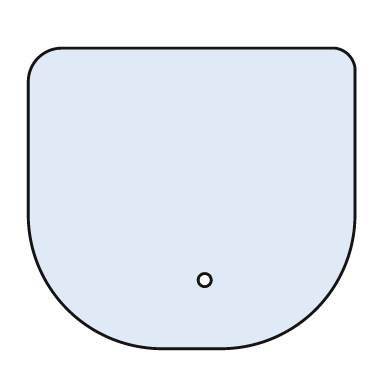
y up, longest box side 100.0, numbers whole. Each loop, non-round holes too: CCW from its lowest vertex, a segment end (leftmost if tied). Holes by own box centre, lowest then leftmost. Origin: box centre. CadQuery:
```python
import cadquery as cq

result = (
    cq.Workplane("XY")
    .moveTo(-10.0, -46.0)
    .lineTo(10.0, -46.0)
    .threePointArc((38.0, -34.0), (50.0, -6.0))
    .lineTo(50.0, 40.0)
    .threePointArc((48.0, 44.0), (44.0, 46.0))
    .lineTo(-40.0, 46.0)
    .threePointArc((-47.0, 43.0), (-50.0, 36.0))
    .lineTo(-50.0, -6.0)
    .threePointArc((-38.0, -34.0), (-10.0, -46.0))
    .close()
    .moveTo(4.0, -25.0)
    .circle(2.0)
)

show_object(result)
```